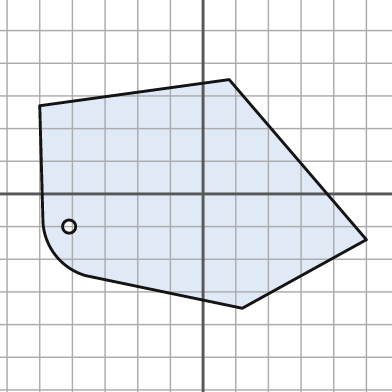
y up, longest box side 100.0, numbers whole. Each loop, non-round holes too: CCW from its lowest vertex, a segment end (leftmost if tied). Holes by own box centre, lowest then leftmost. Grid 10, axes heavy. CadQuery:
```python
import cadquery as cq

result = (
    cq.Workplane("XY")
    .moveTo(12.0, -35.0)
    .lineTo(50.0, -14.0)
    .lineTo(8.0, 35.0)
    .lineTo(-50.0, 27.0)
    .lineTo(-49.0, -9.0)
    .threePointArc((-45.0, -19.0), (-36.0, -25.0))
    .close()
    .moveTo(-41.0, -10.0)
    .circle(2.0)
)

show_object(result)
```